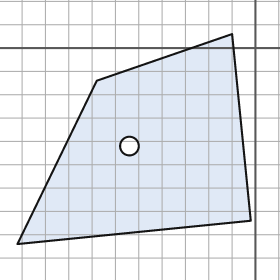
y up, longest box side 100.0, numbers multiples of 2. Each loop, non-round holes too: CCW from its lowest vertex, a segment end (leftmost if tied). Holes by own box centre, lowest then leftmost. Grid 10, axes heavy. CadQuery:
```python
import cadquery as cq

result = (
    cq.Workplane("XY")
    .moveTo(-102.0, -84.0)
    .lineTo(-2.0, -74.0)
    .lineTo(-10.0, 6.0)
    .lineTo(-68.0, -14.0)
    .close()
    .moveTo(-54.0, -42.0)
    .circle(4.0)
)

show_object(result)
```